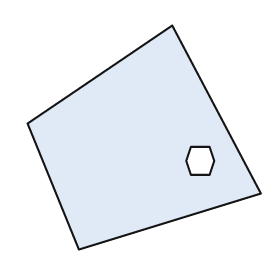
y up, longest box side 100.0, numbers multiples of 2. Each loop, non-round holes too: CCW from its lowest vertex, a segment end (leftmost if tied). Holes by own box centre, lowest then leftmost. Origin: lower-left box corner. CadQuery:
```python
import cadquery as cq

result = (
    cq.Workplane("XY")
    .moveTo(22.0, 0.0)
    .lineTo(100.0, 24.0)
    .lineTo(62.0, 96.0)
    .lineTo(0.0, 54.0)
    .close()
    .moveTo(70.0, 32.0)
    .lineTo(78.0, 32.0)
    .lineTo(80.0, 38.0)
    .lineTo(78.0, 44.0)
    .lineTo(70.0, 44.0)
    .lineTo(68.0, 38.0)
    .close()
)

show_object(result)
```